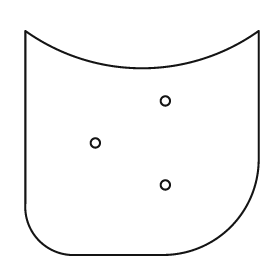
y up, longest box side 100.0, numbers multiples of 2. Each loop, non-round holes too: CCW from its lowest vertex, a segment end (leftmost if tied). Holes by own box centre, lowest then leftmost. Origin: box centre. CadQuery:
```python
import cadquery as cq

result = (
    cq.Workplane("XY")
    .moveTo(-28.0, -48.0)
    .lineTo(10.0, -48.0)
    .threePointArc((38.0, -36.0), (50.0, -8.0))
    .lineTo(50.0, 48.0)
    .threePointArc((0.0, 32.0), (-50.0, 48.0))
    .lineTo(-50.0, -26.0)
    .threePointArc((-44.0, -42.0), (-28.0, -48.0))
    .close()
    .moveTo(10.0, -18.0)
    .circle(2.0)
    .moveTo(-20.0, 0.0)
    .circle(2.0)
    .moveTo(10.0, 18.0)
    .circle(2.0)
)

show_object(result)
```